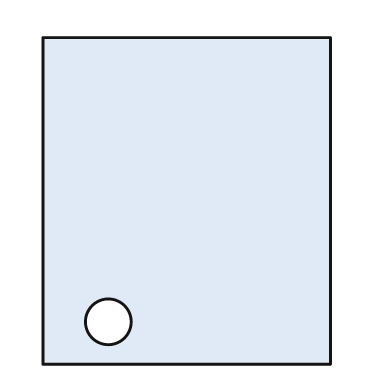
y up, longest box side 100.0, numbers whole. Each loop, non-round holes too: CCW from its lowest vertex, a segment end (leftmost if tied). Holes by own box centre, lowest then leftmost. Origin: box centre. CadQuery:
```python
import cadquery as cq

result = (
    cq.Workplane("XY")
    .moveTo(-44.0, -50.0)
    .lineTo(44.0, -50.0)
    .lineTo(44.0, 50.0)
    .lineTo(-44.0, 50.0)
    .close()
    .moveTo(-24.0, -37.0)
    .circle(7.0)
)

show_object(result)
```